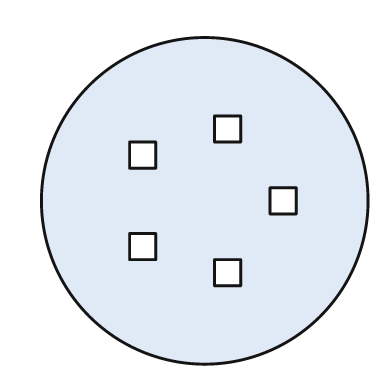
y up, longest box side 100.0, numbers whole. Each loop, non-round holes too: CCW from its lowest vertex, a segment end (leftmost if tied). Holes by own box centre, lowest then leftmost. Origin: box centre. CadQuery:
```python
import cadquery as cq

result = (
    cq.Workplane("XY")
    .moveTo(0.0, 0.0)
    .circle(50.0)
    .moveTo(3.0, -26.0)
    .lineTo(11.0, -26.0)
    .lineTo(11.0, -18.0)
    .lineTo(3.0, -18.0)
    .close()
    .moveTo(-23.0, -18.0)
    .lineTo(-15.0, -18.0)
    .lineTo(-15.0, -10.0)
    .lineTo(-23.0, -10.0)
    .close()
    .moveTo(20.0, -4.0)
    .lineTo(28.0, -4.0)
    .lineTo(28.0, 4.0)
    .lineTo(20.0, 4.0)
    .close()
    .moveTo(-23.0, 10.0)
    .lineTo(-15.0, 10.0)
    .lineTo(-15.0, 18.0)
    .lineTo(-23.0, 18.0)
    .close()
    .moveTo(3.0, 18.0)
    .lineTo(11.0, 18.0)
    .lineTo(11.0, 26.0)
    .lineTo(3.0, 26.0)
    .close()
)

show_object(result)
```